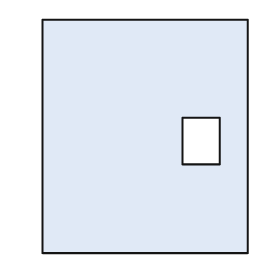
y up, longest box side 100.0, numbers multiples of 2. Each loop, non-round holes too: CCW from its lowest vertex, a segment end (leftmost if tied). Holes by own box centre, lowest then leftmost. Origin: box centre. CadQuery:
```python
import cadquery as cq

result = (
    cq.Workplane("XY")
    .moveTo(-44.0, -50.0)
    .lineTo(44.0, -50.0)
    .lineTo(44.0, 50.0)
    .lineTo(-44.0, 50.0)
    .close()
    .moveTo(16.0, -12.0)
    .lineTo(32.0, -12.0)
    .lineTo(32.0, 8.0)
    .lineTo(16.0, 8.0)
    .close()
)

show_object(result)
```